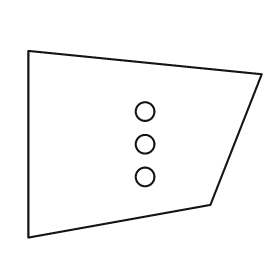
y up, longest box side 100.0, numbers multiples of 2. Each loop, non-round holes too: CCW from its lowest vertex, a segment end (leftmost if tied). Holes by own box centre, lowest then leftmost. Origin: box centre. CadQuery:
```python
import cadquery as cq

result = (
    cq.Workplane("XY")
    .moveTo(-50.0, -40.0)
    .lineTo(28.0, -26.0)
    .lineTo(50.0, 30.0)
    .lineTo(-50.0, 40.0)
    .close()
    .moveTo(0.0, -14.0)
    .circle(4.0)
    .moveTo(0.0, 0.0)
    .circle(4.0)
    .moveTo(0.0, 14.0)
    .circle(4.0)
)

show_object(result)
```